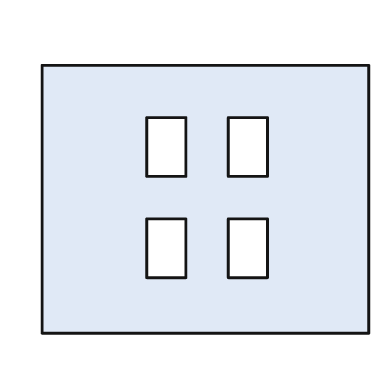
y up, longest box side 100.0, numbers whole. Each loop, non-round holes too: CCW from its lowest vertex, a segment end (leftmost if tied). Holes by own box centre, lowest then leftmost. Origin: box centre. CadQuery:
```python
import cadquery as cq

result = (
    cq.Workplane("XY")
    .moveTo(-50.0, -41.0)
    .lineTo(50.0, -41.0)
    .lineTo(50.0, 41.0)
    .lineTo(-50.0, 41.0)
    .close()
    .moveTo(-18.0, -24.0)
    .lineTo(-6.0, -24.0)
    .lineTo(-6.0, -6.0)
    .lineTo(-18.0, -6.0)
    .close()
    .moveTo(7.0, -24.0)
    .lineTo(19.0, -24.0)
    .lineTo(19.0, -6.0)
    .lineTo(7.0, -6.0)
    .close()
    .moveTo(-18.0, 7.0)
    .lineTo(-6.0, 7.0)
    .lineTo(-6.0, 25.0)
    .lineTo(-18.0, 25.0)
    .close()
    .moveTo(7.0, 7.0)
    .lineTo(19.0, 7.0)
    .lineTo(19.0, 25.0)
    .lineTo(7.0, 25.0)
    .close()
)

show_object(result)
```